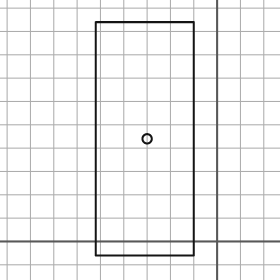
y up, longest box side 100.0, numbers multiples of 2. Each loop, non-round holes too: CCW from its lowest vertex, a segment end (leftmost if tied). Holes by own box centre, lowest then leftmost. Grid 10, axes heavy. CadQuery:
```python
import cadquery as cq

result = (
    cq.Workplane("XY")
    .moveTo(-52.0, -6.0)
    .lineTo(-10.0, -6.0)
    .lineTo(-10.0, 94.0)
    .lineTo(-52.0, 94.0)
    .close()
    .moveTo(-30.0, 44.0)
    .circle(2.0)
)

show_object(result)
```